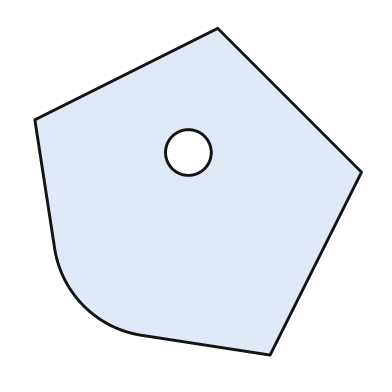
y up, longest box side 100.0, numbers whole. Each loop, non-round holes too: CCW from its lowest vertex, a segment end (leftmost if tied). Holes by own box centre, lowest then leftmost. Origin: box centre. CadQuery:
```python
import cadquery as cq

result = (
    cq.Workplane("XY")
    .moveTo(22.0, -50.0)
    .lineTo(50.0, 6.0)
    .lineTo(6.0, 50.0)
    .lineTo(-50.0, 22.0)
    .lineTo(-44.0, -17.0)
    .threePointArc((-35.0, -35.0), (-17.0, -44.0))
    .close()
    .moveTo(-3.0, 12.0)
    .circle(7.0)
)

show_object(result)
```